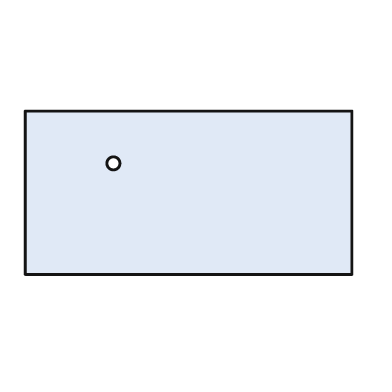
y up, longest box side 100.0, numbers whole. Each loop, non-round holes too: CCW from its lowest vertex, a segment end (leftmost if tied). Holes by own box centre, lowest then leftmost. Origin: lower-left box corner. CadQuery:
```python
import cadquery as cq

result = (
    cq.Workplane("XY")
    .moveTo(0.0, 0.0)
    .lineTo(100.0, 0.0)
    .lineTo(100.0, 50.0)
    .lineTo(0.0, 50.0)
    .close()
    .moveTo(27.0, 34.0)
    .circle(2.0)
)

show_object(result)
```